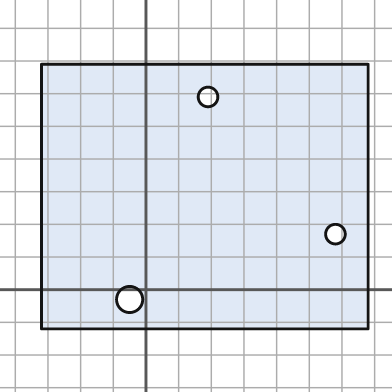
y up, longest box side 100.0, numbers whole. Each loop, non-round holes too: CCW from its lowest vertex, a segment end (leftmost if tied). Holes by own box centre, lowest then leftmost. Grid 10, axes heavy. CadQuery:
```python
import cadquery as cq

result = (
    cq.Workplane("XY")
    .moveTo(-32.0, -12.0)
    .lineTo(68.0, -12.0)
    .lineTo(68.0, 69.0)
    .lineTo(-32.0, 69.0)
    .close()
    .moveTo(-5.0, -3.0)
    .circle(4.0)
    .moveTo(58.0, 17.0)
    .circle(3.0)
    .moveTo(19.0, 59.0)
    .circle(3.0)
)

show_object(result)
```